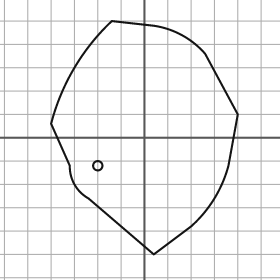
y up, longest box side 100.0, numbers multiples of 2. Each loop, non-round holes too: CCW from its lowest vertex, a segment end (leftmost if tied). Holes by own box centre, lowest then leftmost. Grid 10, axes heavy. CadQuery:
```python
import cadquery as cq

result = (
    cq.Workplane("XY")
    .moveTo(4.0, -50.0)
    .lineTo(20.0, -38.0)
    .threePointArc((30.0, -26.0), (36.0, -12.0))
    .lineTo(40.0, 10.0)
    .lineTo(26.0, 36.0)
    .threePointArc((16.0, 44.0), (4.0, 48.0))
    .lineTo(-14.0, 50.0)
    .threePointArc((-30.0, 30.0), (-40.0, 6.0))
    .lineTo(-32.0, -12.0)
    .threePointArc((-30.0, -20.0), (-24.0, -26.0))
    .close()
    .moveTo(-20.0, -12.0)
    .circle(2.0)
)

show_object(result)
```